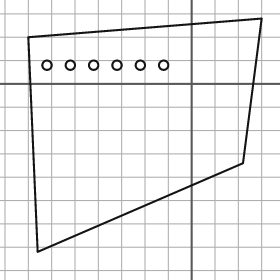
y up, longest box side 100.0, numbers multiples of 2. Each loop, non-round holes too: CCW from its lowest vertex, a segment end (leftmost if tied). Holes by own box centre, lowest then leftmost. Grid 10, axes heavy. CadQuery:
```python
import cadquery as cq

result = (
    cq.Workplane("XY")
    .moveTo(-66.0, -72.0)
    .lineTo(22.0, -34.0)
    .lineTo(30.0, 28.0)
    .lineTo(-70.0, 20.0)
    .close()
    .moveTo(-62.0, 8.0)
    .circle(2.0)
    .moveTo(-52.0, 8.0)
    .circle(2.0)
    .moveTo(-42.0, 8.0)
    .circle(2.0)
    .moveTo(-32.0, 8.0)
    .circle(2.0)
    .moveTo(-22.0, 8.0)
    .circle(2.0)
    .moveTo(-12.0, 8.0)
    .circle(2.0)
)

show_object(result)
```